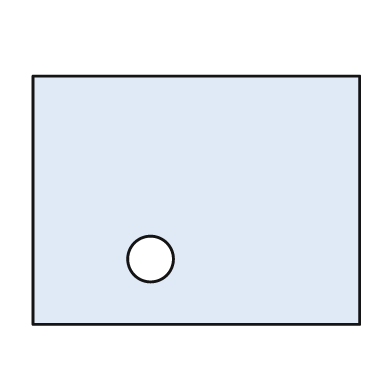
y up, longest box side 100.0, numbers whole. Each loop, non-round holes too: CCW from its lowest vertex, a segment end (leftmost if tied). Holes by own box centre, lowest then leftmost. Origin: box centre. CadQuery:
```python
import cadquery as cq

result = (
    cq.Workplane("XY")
    .moveTo(-50.0, -38.0)
    .lineTo(50.0, -38.0)
    .lineTo(50.0, 38.0)
    .lineTo(-50.0, 38.0)
    .close()
    .moveTo(-14.0, -18.0)
    .circle(7.0)
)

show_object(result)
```